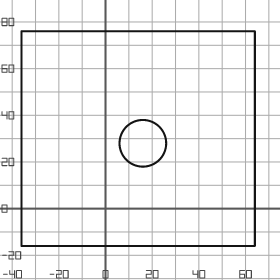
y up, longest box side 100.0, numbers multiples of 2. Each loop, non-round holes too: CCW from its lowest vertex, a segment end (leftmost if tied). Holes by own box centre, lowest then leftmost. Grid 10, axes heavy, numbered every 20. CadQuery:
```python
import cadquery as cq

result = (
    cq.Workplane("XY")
    .moveTo(-36.0, -16.0)
    .lineTo(64.0, -16.0)
    .lineTo(64.0, 76.0)
    .lineTo(-36.0, 76.0)
    .close()
    .moveTo(16.0, 28.0)
    .circle(10.0)
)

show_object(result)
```